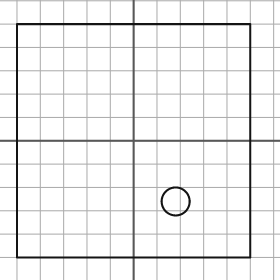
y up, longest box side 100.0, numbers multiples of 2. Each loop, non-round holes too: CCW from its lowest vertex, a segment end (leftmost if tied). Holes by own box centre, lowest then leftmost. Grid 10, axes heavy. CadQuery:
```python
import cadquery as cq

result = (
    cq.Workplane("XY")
    .moveTo(-50.0, -50.0)
    .lineTo(50.0, -50.0)
    .lineTo(50.0, 50.0)
    .lineTo(-50.0, 50.0)
    .close()
    .moveTo(18.0, -26.0)
    .circle(6.0)
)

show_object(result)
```